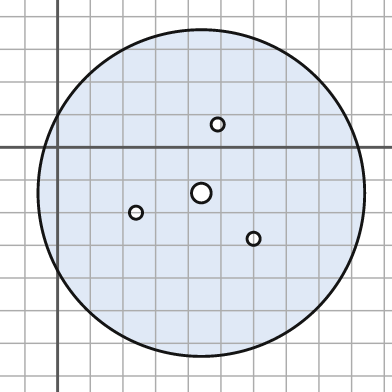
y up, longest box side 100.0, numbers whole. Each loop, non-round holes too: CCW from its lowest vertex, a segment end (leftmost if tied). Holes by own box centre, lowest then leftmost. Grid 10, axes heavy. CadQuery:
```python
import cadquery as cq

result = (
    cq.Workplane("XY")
    .moveTo(44.0, -14.0)
    .circle(50.0)
    .moveTo(60.0, -28.0)
    .circle(2.0)
    .moveTo(24.0, -20.0)
    .circle(2.0)
    .moveTo(44.0, -14.0)
    .circle(3.0)
    .moveTo(49.0, 7.0)
    .circle(2.0)
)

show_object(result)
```